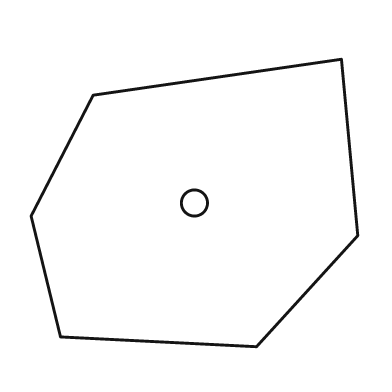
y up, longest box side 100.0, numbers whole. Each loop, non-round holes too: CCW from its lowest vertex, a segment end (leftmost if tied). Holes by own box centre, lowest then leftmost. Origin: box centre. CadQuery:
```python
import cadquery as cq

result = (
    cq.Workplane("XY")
    .moveTo(19.0, -44.0)
    .lineTo(50.0, -10.0)
    .lineTo(45.0, 44.0)
    .lineTo(-31.0, 33.0)
    .lineTo(-50.0, -4.0)
    .lineTo(-41.0, -41.0)
    .close()
    .moveTo(0.0, 0.0)
    .circle(4.0)
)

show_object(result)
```